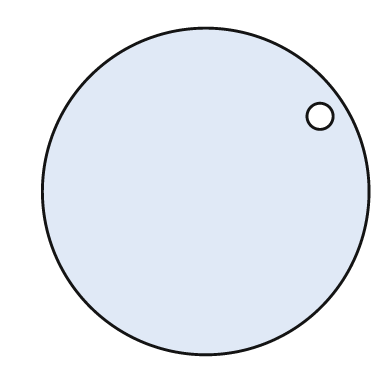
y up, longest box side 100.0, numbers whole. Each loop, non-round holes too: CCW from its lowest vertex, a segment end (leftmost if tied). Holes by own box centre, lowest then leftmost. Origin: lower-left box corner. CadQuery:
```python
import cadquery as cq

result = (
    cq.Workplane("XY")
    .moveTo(50.0, 50.0)
    .circle(50.0)
    .moveTo(85.0, 73.0)
    .circle(4.0)
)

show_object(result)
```